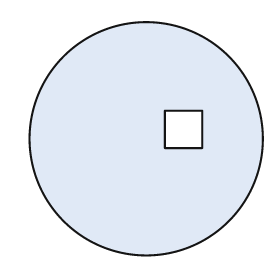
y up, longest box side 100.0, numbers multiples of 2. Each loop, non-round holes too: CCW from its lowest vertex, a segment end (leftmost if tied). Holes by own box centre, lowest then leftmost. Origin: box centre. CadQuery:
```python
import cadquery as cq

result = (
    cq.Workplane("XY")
    .moveTo(0.0, 0.0)
    .circle(50.0)
    .moveTo(8.0, -4.0)
    .lineTo(24.0, -4.0)
    .lineTo(24.0, 12.0)
    .lineTo(8.0, 12.0)
    .close()
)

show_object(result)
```